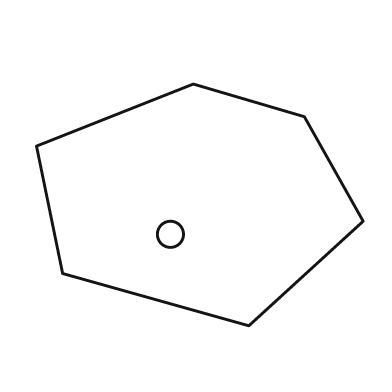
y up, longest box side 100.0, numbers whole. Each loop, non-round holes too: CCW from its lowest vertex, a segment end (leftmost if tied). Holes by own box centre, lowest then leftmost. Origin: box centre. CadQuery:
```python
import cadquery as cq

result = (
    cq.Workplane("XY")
    .moveTo(15.0, -37.0)
    .lineTo(50.0, -5.0)
    .lineTo(32.0, 27.0)
    .lineTo(-2.0, 37.0)
    .lineTo(-50.0, 18.0)
    .lineTo(-42.0, -21.0)
    .close()
    .moveTo(-9.0, -9.0)
    .circle(4.0)
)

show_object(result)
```